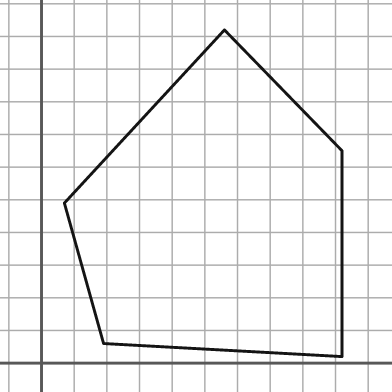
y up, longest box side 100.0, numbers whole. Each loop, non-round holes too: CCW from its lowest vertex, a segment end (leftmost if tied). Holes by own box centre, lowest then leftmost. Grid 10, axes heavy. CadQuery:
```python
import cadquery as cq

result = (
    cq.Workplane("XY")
    .moveTo(92.0, 2.0)
    .lineTo(92.0, 65.0)
    .lineTo(56.0, 102.0)
    .lineTo(7.0, 49.0)
    .lineTo(19.0, 6.0)
    .close()
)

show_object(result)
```